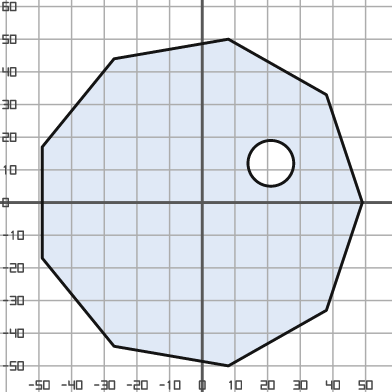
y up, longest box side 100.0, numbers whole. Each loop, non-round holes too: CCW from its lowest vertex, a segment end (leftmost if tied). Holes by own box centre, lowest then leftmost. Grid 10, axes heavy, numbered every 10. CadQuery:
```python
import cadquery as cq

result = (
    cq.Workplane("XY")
    .moveTo(8.0, -50.0)
    .lineTo(38.0, -33.0)
    .lineTo(49.0, 0.0)
    .lineTo(38.0, 33.0)
    .lineTo(8.0, 50.0)
    .lineTo(-27.0, 44.0)
    .lineTo(-49.0, 17.0)
    .lineTo(-49.0, -17.0)
    .lineTo(-27.0, -44.0)
    .close()
    .moveTo(21.0, 12.0)
    .circle(7.0)
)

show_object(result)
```